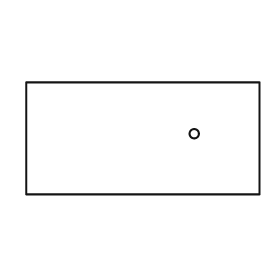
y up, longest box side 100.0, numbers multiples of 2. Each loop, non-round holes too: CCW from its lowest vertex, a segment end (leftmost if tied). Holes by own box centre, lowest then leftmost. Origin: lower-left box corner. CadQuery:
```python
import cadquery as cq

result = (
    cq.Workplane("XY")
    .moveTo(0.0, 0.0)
    .lineTo(100.0, 0.0)
    .lineTo(100.0, 48.0)
    .lineTo(0.0, 48.0)
    .close()
    .moveTo(72.0, 26.0)
    .circle(2.0)
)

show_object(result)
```